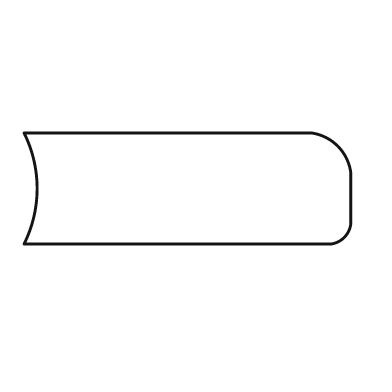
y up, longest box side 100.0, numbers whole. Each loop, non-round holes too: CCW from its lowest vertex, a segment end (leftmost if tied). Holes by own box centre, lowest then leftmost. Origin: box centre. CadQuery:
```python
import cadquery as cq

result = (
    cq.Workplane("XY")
    .moveTo(-50.0, -17.0)
    .lineTo(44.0, -17.0)
    .threePointArc((48.0, -15.0), (50.0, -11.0))
    .lineTo(50.0, 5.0)
    .threePointArc((46.0, 13.0), (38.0, 17.0))
    .lineTo(-50.0, 17.0)
    .threePointArc((-46.0, 0.0), (-50.0, -17.0))
    .close()
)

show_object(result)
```